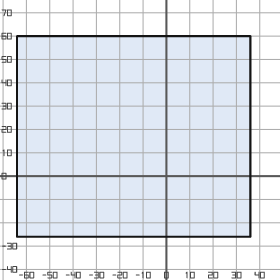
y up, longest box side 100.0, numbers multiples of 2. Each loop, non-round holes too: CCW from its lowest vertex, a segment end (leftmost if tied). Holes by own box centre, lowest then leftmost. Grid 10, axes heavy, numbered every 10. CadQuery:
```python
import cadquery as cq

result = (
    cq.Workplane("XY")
    .moveTo(-64.0, -26.0)
    .lineTo(36.0, -26.0)
    .lineTo(36.0, 60.0)
    .lineTo(-64.0, 60.0)
    .close()
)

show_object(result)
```